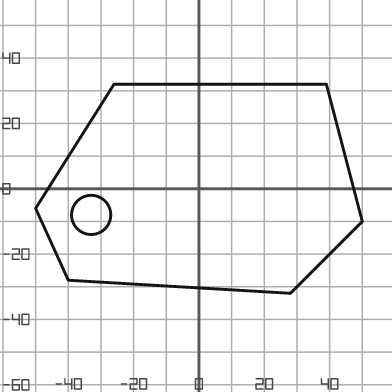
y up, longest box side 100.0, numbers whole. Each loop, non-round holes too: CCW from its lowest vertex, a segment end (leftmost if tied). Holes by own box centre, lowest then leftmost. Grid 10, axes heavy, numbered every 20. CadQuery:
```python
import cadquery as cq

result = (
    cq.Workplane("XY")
    .moveTo(28.0, -32.0)
    .lineTo(50.0, -10.0)
    .lineTo(39.0, 32.0)
    .lineTo(-26.0, 32.0)
    .lineTo(-50.0, -6.0)
    .lineTo(-40.0, -28.0)
    .close()
    .moveTo(-33.0, -8.0)
    .circle(6.0)
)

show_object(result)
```